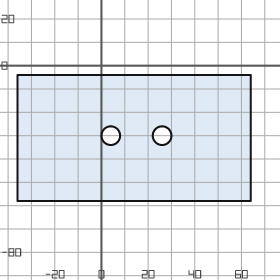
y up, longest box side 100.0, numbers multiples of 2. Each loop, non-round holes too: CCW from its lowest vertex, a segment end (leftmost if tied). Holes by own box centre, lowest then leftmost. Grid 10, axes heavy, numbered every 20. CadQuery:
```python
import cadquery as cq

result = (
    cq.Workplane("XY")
    .moveTo(-36.0, -58.0)
    .lineTo(64.0, -58.0)
    .lineTo(64.0, -4.0)
    .lineTo(-36.0, -4.0)
    .close()
    .moveTo(4.0, -30.0)
    .circle(4.0)
    .moveTo(26.0, -30.0)
    .circle(4.0)
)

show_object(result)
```